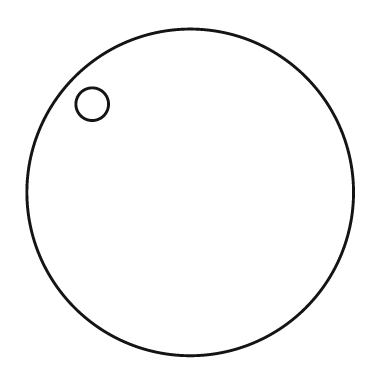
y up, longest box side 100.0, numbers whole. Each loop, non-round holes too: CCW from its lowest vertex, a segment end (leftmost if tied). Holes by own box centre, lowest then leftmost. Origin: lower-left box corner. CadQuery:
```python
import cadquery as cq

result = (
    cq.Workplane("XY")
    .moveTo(50.0, 50.0)
    .circle(50.0)
    .moveTo(20.0, 77.0)
    .circle(5.0)
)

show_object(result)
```